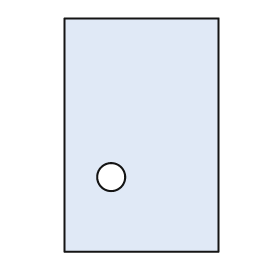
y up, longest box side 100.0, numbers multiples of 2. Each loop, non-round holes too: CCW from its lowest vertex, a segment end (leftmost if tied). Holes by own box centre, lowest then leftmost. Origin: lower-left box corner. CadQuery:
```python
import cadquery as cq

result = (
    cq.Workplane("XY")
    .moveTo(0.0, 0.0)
    .lineTo(66.0, 0.0)
    .lineTo(66.0, 100.0)
    .lineTo(0.0, 100.0)
    .close()
    .moveTo(20.0, 32.0)
    .circle(6.0)
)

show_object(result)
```